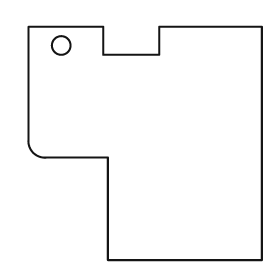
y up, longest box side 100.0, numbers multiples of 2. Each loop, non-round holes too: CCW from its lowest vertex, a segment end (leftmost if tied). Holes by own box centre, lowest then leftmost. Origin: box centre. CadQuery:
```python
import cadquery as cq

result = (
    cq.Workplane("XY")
    .moveTo(-16.0, -50.0)
    .lineTo(50.0, -50.0)
    .lineTo(50.0, 50.0)
    .lineTo(6.0, 50.0)
    .lineTo(6.0, 38.0)
    .lineTo(-18.0, 38.0)
    .lineTo(-18.0, 50.0)
    .lineTo(-50.0, 50.0)
    .lineTo(-50.0, 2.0)
    .threePointArc((-48.0, -4.0), (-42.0, -6.0))
    .lineTo(-16.0, -6.0)
    .close()
    .moveTo(-36.0, 42.0)
    .circle(4.0)
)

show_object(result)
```